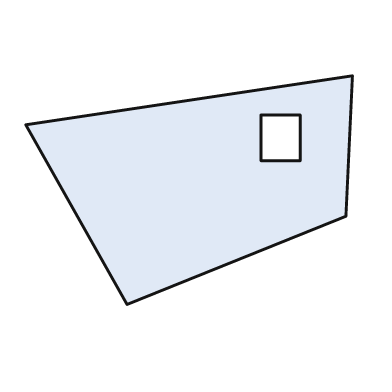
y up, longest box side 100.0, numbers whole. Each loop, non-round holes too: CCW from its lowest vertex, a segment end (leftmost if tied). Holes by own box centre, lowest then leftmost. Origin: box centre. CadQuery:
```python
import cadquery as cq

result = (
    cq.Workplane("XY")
    .moveTo(-19.0, -35.0)
    .lineTo(48.0, -8.0)
    .lineTo(50.0, 35.0)
    .lineTo(-50.0, 20.0)
    .close()
    .moveTo(22.0, 9.0)
    .lineTo(34.0, 9.0)
    .lineTo(34.0, 23.0)
    .lineTo(22.0, 23.0)
    .close()
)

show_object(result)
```